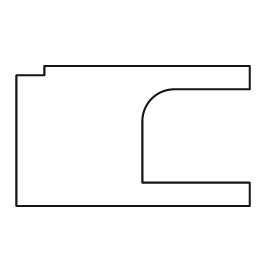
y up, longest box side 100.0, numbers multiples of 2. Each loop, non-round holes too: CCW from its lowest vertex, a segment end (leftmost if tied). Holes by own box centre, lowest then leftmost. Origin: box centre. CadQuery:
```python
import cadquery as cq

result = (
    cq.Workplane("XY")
    .moveTo(-50.0, -30.0)
    .lineTo(50.0, -30.0)
    .lineTo(50.0, -20.0)
    .lineTo(4.0, -20.0)
    .lineTo(4.0, 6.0)
    .threePointArc((8.0, 16.0), (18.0, 20.0))
    .lineTo(50.0, 20.0)
    .lineTo(50.0, 30.0)
    .lineTo(-38.0, 30.0)
    .lineTo(-38.0, 26.0)
    .lineTo(-50.0, 26.0)
    .close()
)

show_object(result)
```